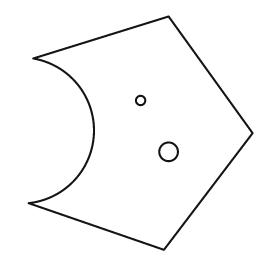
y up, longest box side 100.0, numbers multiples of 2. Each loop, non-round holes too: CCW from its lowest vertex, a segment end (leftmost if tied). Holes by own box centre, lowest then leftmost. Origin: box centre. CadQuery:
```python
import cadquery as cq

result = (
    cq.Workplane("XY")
    .moveTo(10.0, -50.0)
    .lineTo(48.0, 0.0)
    .lineTo(12.0, 50.0)
    .lineTo(-46.0, 32.0)
    .threePointArc((-20.0, 0.0), (-48.0, -30.0))
    .close()
    .moveTo(12.0, -8.0)
    .circle(4.0)
    .moveTo(0.0, 14.0)
    .circle(2.0)
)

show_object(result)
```